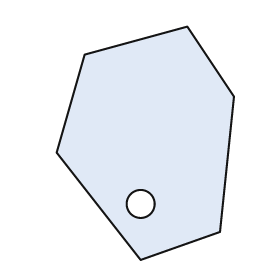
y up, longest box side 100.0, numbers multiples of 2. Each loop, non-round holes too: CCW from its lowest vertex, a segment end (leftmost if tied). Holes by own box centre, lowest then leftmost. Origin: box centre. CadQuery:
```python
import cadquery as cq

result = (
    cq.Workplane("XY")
    .moveTo(-2.0, -50.0)
    .lineTo(32.0, -38.0)
    .lineTo(38.0, 20.0)
    .lineTo(18.0, 50.0)
    .lineTo(-26.0, 38.0)
    .lineTo(-38.0, -4.0)
    .close()
    .moveTo(-2.0, -26.0)
    .circle(6.0)
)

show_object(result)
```